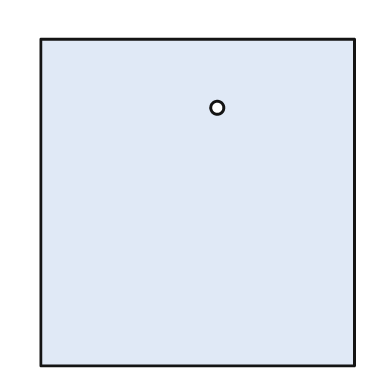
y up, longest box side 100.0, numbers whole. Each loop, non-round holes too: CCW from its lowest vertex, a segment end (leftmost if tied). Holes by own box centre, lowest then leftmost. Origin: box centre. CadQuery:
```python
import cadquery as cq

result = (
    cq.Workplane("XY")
    .moveTo(-48.0, -50.0)
    .lineTo(48.0, -50.0)
    .lineTo(48.0, 50.0)
    .lineTo(-48.0, 50.0)
    .close()
    .moveTo(6.0, 29.0)
    .circle(2.0)
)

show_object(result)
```